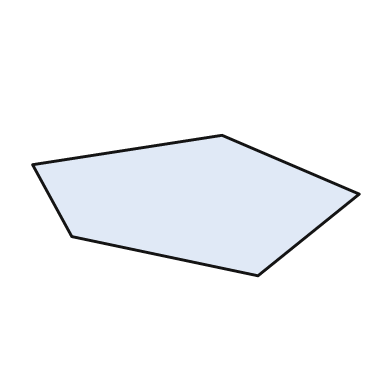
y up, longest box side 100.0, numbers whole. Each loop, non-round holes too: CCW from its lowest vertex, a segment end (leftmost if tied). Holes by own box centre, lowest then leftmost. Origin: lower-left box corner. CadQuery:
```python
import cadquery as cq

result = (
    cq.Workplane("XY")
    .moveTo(69.0, 0.0)
    .lineTo(100.0, 25.0)
    .lineTo(58.0, 43.0)
    .lineTo(0.0, 34.0)
    .lineTo(12.0, 12.0)
    .close()
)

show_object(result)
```